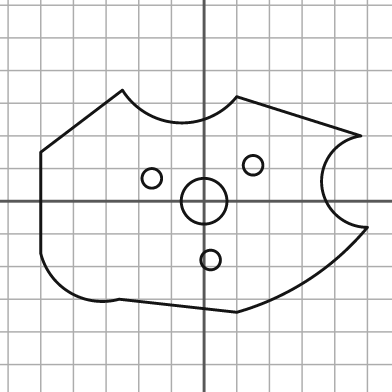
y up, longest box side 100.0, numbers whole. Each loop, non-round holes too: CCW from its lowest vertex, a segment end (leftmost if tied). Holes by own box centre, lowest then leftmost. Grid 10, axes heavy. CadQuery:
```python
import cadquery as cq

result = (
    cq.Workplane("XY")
    .moveTo(10.0, -34.0)
    .threePointArc((32.0, -24.0), (50.0, -8.0))
    .threePointArc((36.0, 5.0), (48.0, 20.0))
    .lineTo(10.0, 32.0)
    .threePointArc((-8.0, 24.0), (-25.0, 34.0))
    .lineTo(-50.0, 15.0)
    .lineTo(-50.0, -16.0)
    .threePointArc((-41.0, -28.0), (-26.0, -30.0))
    .close()
    .moveTo(2.0, -18.0)
    .circle(3.0)
    .moveTo(0.0, 0.0)
    .circle(7.0)
    .moveTo(-16.0, 7.0)
    .circle(3.0)
    .moveTo(15.0, 11.0)
    .circle(3.0)
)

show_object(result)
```